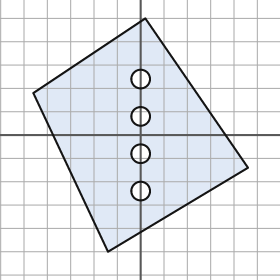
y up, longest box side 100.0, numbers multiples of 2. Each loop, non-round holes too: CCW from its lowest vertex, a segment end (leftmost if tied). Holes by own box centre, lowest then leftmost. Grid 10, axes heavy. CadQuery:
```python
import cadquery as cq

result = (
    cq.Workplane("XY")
    .moveTo(-14.0, -50.0)
    .lineTo(46.0, -14.0)
    .lineTo(2.0, 50.0)
    .lineTo(-46.0, 18.0)
    .close()
    .moveTo(0.0, -24.0)
    .circle(4.0)
    .moveTo(0.0, -8.0)
    .circle(4.0)
    .moveTo(0.0, 8.0)
    .circle(4.0)
    .moveTo(0.0, 24.0)
    .circle(4.0)
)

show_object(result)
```